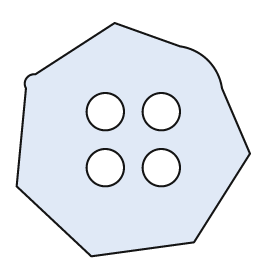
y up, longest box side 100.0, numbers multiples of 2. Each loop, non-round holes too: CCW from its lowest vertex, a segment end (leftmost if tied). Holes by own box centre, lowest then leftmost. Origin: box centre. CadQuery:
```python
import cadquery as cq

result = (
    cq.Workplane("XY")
    .moveTo(-18.0, -50.0)
    .lineTo(26.0, -44.0)
    .lineTo(50.0, -6.0)
    .lineTo(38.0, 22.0)
    .threePointArc((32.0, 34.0), (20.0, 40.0))
    .lineTo(-8.0, 50.0)
    .lineTo(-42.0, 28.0)
    .threePointArc((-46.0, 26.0), (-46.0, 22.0))
    .lineTo(-50.0, -20.0)
    .close()
    .moveTo(-12.0, -12.0)
    .circle(8.0)
    .moveTo(12.0, -12.0)
    .circle(8.0)
    .moveTo(-12.0, 12.0)
    .circle(8.0)
    .moveTo(12.0, 12.0)
    .circle(8.0)
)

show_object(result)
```